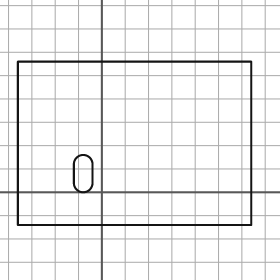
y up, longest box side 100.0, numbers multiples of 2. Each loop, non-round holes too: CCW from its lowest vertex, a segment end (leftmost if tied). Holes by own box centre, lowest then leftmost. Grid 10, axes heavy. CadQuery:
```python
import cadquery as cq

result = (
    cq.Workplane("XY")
    .moveTo(-36.0, -14.0)
    .lineTo(64.0, -14.0)
    .lineTo(64.0, 56.0)
    .lineTo(-36.0, 56.0)
    .close()
    .moveTo(-12.0, 4.0)
    .threePointArc((-8.0, 0.0), (-4.0, 4.0))
    .lineTo(-4.0, 12.0)
    .threePointArc((-8.0, 16.0), (-12.0, 12.0))
    .close()
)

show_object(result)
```